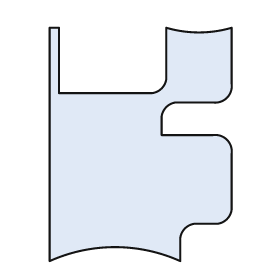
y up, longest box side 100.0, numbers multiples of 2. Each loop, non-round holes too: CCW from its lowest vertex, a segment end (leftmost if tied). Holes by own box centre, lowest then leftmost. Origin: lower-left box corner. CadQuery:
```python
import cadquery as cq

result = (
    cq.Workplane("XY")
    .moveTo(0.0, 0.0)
    .threePointArc((28.0, 6.0), (56.0, 0.0))
    .lineTo(56.0, 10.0)
    .threePointArc((58.0, 14.0), (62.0, 16.0))
    .lineTo(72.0, 16.0)
    .threePointArc((76.0, 18.0), (78.0, 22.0))
    .lineTo(78.0, 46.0)
    .threePointArc((76.0, 52.0), (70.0, 54.0))
    .lineTo(48.0, 54.0)
    .lineTo(48.0, 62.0)
    .threePointArc((50.0, 66.0), (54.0, 68.0))
    .lineTo(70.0, 68.0)
    .threePointArc((76.0, 70.0), (78.0, 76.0))
    .lineTo(78.0, 100.0)
    .threePointArc((64.0, 98.0), (50.0, 100.0))
    .lineTo(50.0, 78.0)
    .threePointArc((48.0, 74.0), (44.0, 72.0))
    .lineTo(4.0, 72.0)
    .lineTo(4.0, 100.0)
    .lineTo(0.0, 100.0)
    .close()
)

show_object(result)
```